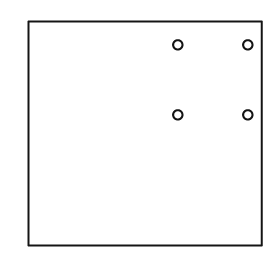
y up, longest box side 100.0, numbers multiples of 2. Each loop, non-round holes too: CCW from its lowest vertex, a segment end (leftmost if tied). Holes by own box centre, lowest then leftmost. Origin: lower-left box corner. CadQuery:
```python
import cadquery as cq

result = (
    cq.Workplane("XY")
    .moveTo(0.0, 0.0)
    .lineTo(100.0, 0.0)
    .lineTo(100.0, 96.0)
    .lineTo(0.0, 96.0)
    .close()
    .moveTo(64.0, 56.0)
    .circle(2.0)
    .moveTo(94.0, 56.0)
    .circle(2.0)
    .moveTo(64.0, 86.0)
    .circle(2.0)
    .moveTo(94.0, 86.0)
    .circle(2.0)
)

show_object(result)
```